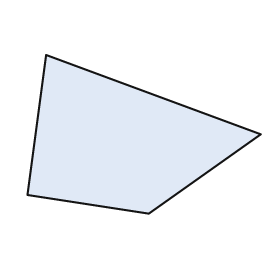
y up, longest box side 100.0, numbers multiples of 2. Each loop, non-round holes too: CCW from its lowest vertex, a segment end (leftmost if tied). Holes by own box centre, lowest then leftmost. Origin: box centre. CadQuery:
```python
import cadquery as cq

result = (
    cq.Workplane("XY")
    .moveTo(2.0, -34.0)
    .lineTo(50.0, 0.0)
    .lineTo(-42.0, 34.0)
    .lineTo(-50.0, -26.0)
    .close()
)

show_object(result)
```